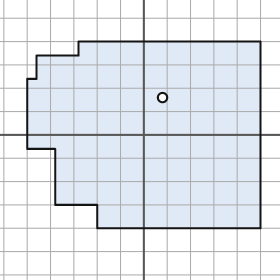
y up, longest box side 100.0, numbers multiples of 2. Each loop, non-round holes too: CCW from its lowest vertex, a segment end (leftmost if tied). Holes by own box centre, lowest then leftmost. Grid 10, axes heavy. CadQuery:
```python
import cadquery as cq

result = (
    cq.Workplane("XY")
    .moveTo(-20.0, -40.0)
    .lineTo(50.0, -40.0)
    .lineTo(50.0, 40.0)
    .lineTo(-28.0, 40.0)
    .lineTo(-28.0, 34.0)
    .lineTo(-46.0, 34.0)
    .lineTo(-46.0, 24.0)
    .lineTo(-50.0, 24.0)
    .lineTo(-50.0, -6.0)
    .lineTo(-38.0, -6.0)
    .lineTo(-38.0, -30.0)
    .lineTo(-20.0, -30.0)
    .close()
    .moveTo(8.0, 16.0)
    .circle(2.0)
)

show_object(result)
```